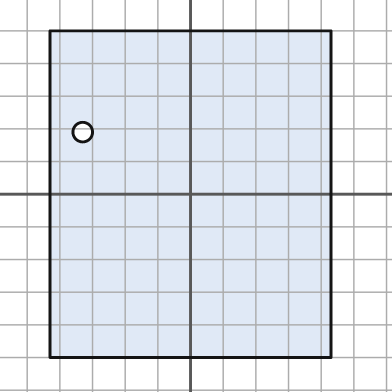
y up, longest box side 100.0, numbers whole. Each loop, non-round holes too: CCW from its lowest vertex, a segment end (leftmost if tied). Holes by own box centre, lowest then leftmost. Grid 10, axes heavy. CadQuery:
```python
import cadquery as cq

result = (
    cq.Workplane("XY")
    .moveTo(-43.0, -50.0)
    .lineTo(43.0, -50.0)
    .lineTo(43.0, 50.0)
    .lineTo(-43.0, 50.0)
    .close()
    .moveTo(-33.0, 19.0)
    .circle(3.0)
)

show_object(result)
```